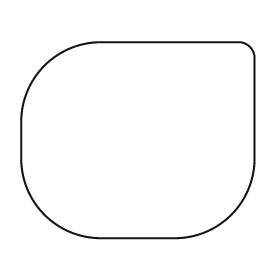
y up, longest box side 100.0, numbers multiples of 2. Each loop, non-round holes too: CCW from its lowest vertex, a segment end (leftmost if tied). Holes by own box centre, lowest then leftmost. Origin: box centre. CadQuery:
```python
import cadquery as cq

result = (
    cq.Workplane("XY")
    .moveTo(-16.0, -42.0)
    .lineTo(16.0, -42.0)
    .threePointArc((40.0, -32.0), (50.0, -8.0))
    .lineTo(50.0, 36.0)
    .threePointArc((48.0, 40.0), (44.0, 42.0))
    .lineTo(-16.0, 42.0)
    .threePointArc((-40.0, 32.0), (-50.0, 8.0))
    .lineTo(-50.0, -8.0)
    .threePointArc((-40.0, -32.0), (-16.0, -42.0))
    .close()
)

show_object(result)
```